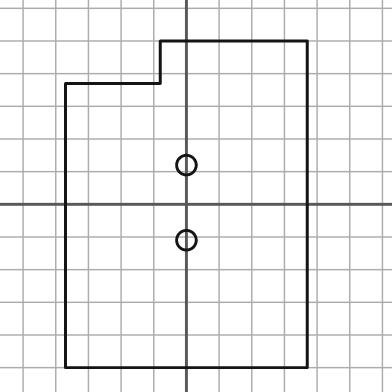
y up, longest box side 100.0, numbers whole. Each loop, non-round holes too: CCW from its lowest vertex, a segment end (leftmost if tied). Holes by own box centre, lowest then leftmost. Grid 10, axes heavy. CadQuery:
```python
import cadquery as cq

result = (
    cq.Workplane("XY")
    .moveTo(-37.0, -50.0)
    .lineTo(37.0, -50.0)
    .lineTo(37.0, 50.0)
    .lineTo(-8.0, 50.0)
    .lineTo(-8.0, 37.0)
    .lineTo(-37.0, 37.0)
    .close()
    .moveTo(0.0, -11.0)
    .circle(3.0)
    .moveTo(0.0, 12.0)
    .circle(3.0)
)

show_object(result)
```